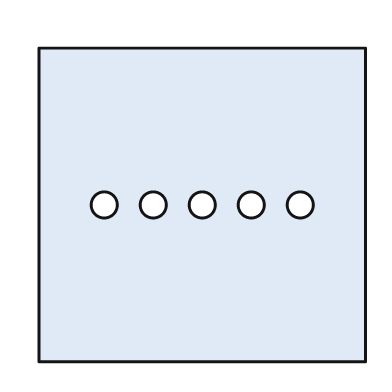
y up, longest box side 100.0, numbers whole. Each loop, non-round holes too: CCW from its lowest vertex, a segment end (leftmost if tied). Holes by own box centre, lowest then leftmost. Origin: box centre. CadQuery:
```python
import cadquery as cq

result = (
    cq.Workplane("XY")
    .moveTo(-50.0, -48.0)
    .lineTo(50.0, -48.0)
    .lineTo(50.0, 48.0)
    .lineTo(-50.0, 48.0)
    .close()
    .moveTo(-30.0, 0.0)
    .circle(4.0)
    .moveTo(-15.0, 0.0)
    .circle(4.0)
    .moveTo(0.0, 0.0)
    .circle(4.0)
    .moveTo(15.0, 0.0)
    .circle(4.0)
    .moveTo(30.0, 0.0)
    .circle(4.0)
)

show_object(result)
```